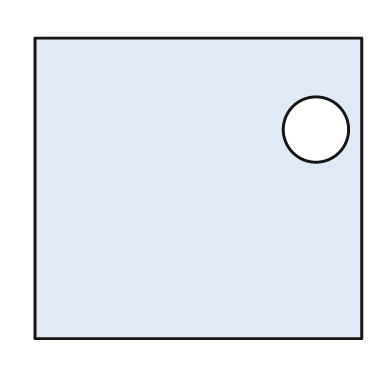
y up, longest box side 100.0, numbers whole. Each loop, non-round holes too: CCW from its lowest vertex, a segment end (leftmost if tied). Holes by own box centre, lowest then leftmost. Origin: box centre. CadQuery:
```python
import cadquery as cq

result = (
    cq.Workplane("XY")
    .moveTo(-50.0, -46.0)
    .lineTo(50.0, -46.0)
    .lineTo(50.0, 46.0)
    .lineTo(-50.0, 46.0)
    .close()
    .moveTo(36.0, 18.0)
    .circle(10.0)
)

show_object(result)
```